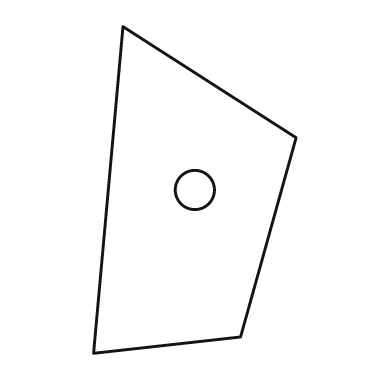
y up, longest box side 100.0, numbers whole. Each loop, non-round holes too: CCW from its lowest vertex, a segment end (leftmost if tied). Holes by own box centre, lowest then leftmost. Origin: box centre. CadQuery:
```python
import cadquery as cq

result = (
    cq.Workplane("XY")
    .moveTo(-31.0, -50.0)
    .lineTo(14.0, -45.0)
    .lineTo(31.0, 16.0)
    .lineTo(-22.0, 50.0)
    .close()
    .moveTo(0.0, 0.0)
    .circle(6.0)
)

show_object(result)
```